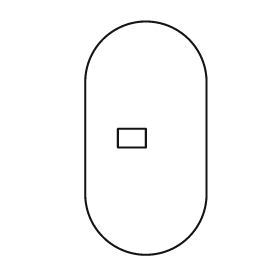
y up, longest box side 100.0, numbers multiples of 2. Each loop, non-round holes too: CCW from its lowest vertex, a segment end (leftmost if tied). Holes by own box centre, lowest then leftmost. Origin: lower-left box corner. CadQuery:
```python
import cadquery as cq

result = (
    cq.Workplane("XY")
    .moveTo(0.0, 26.0)
    .threePointArc((26.0, 0.0), (52.0, 26.0))
    .lineTo(52.0, 74.0)
    .threePointArc((26.0, 100.0), (0.0, 74.0))
    .close()
    .moveTo(14.0, 46.0)
    .lineTo(26.0, 46.0)
    .lineTo(26.0, 54.0)
    .lineTo(14.0, 54.0)
    .close()
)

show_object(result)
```